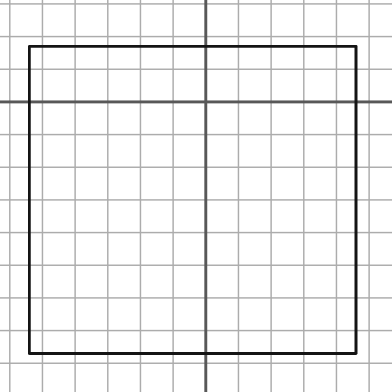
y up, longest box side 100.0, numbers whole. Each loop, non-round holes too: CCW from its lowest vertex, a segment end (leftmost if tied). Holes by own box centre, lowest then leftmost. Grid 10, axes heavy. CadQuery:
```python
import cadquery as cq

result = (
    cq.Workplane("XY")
    .moveTo(-54.0, -77.0)
    .lineTo(46.0, -77.0)
    .lineTo(46.0, 17.0)
    .lineTo(-54.0, 17.0)
    .close()
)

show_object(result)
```